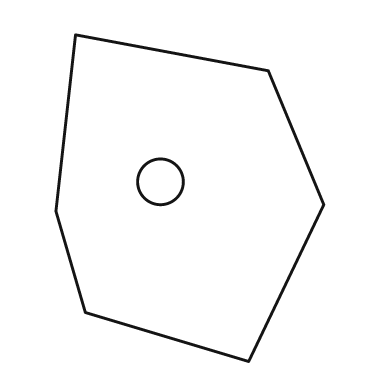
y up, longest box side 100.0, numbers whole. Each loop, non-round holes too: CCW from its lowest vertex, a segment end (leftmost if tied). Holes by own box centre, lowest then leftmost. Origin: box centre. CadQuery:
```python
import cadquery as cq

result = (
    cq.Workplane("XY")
    .moveTo(18.0, -50.0)
    .lineTo(41.0, -2.0)
    .lineTo(24.0, 39.0)
    .lineTo(-35.0, 50.0)
    .lineTo(-41.0, -4.0)
    .lineTo(-32.0, -35.0)
    .close()
    .moveTo(-9.0, 5.0)
    .circle(7.0)
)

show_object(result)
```